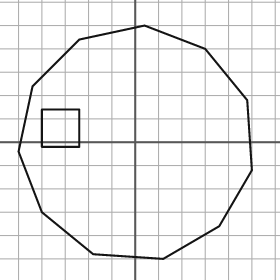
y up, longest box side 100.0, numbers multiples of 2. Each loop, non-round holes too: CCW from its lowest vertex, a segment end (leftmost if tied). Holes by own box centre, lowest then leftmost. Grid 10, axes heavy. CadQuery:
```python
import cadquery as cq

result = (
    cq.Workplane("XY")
    .moveTo(12.0, -50.0)
    .lineTo(36.0, -36.0)
    .lineTo(50.0, -12.0)
    .lineTo(48.0, 18.0)
    .lineTo(30.0, 40.0)
    .lineTo(4.0, 50.0)
    .lineTo(-24.0, 44.0)
    .lineTo(-44.0, 24.0)
    .lineTo(-50.0, -4.0)
    .lineTo(-40.0, -30.0)
    .lineTo(-18.0, -48.0)
    .close()
    .moveTo(-40.0, -2.0)
    .lineTo(-24.0, -2.0)
    .lineTo(-24.0, 14.0)
    .lineTo(-40.0, 14.0)
    .close()
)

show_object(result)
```